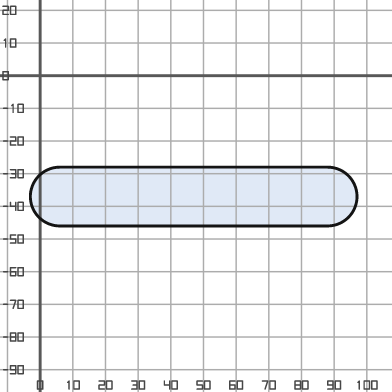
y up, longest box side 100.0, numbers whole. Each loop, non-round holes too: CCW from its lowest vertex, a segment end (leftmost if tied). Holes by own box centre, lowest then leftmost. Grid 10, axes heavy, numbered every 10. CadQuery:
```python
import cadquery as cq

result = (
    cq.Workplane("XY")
    .moveTo(6.0, -46.0)
    .lineTo(88.0, -46.0)
    .threePointArc((97.0, -37.0), (88.0, -28.0))
    .lineTo(6.0, -28.0)
    .threePointArc((-3.0, -37.0), (6.0, -46.0))
    .close()
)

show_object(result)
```